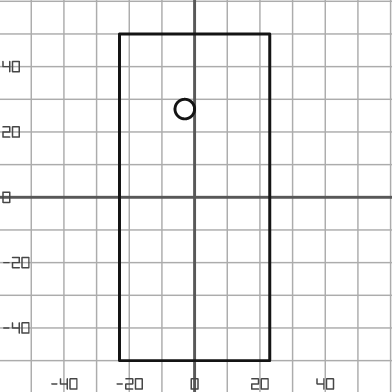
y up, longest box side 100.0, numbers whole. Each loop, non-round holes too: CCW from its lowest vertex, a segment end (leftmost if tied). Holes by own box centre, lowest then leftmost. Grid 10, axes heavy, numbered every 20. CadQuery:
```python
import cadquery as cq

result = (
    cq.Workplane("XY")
    .moveTo(-23.0, -50.0)
    .lineTo(23.0, -50.0)
    .lineTo(23.0, 50.0)
    .lineTo(-23.0, 50.0)
    .close()
    .moveTo(-3.0, 27.0)
    .circle(3.0)
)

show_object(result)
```